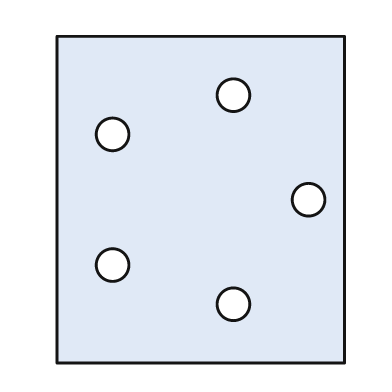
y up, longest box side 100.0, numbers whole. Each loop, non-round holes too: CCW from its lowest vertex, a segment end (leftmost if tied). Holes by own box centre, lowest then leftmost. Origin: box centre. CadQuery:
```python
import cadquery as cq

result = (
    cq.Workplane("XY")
    .moveTo(-44.0, -50.0)
    .lineTo(44.0, -50.0)
    .lineTo(44.0, 50.0)
    .lineTo(-44.0, 50.0)
    .close()
    .moveTo(10.0, -32.0)
    .circle(5.0)
    .moveTo(-27.0, -20.0)
    .circle(5.0)
    .moveTo(33.0, 0.0)
    .circle(5.0)
    .moveTo(-27.0, 20.0)
    .circle(5.0)
    .moveTo(10.0, 32.0)
    .circle(5.0)
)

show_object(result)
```